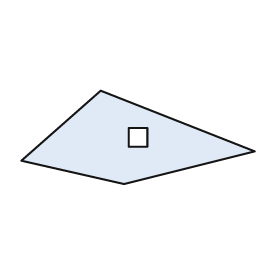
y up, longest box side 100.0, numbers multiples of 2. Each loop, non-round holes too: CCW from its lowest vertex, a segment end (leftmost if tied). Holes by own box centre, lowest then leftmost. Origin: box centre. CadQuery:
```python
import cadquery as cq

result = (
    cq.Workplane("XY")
    .moveTo(-6.0, -20.0)
    .lineTo(50.0, -6.0)
    .lineTo(-16.0, 20.0)
    .lineTo(-50.0, -10.0)
    .close()
    .moveTo(-4.0, -4.0)
    .lineTo(4.0, -4.0)
    .lineTo(4.0, 4.0)
    .lineTo(-4.0, 4.0)
    .close()
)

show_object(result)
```